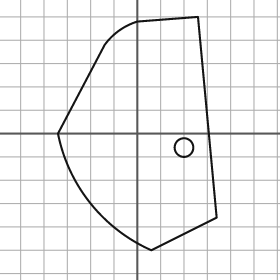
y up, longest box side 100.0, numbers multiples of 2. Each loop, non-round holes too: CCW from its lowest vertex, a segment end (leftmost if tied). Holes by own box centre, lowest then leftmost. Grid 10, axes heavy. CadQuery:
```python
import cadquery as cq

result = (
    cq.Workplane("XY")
    .moveTo(6.0, -50.0)
    .lineTo(34.0, -36.0)
    .lineTo(26.0, 50.0)
    .lineTo(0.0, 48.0)
    .threePointArc((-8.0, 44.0), (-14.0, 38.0))
    .lineTo(-34.0, 0.0)
    .threePointArc((-20.0, -30.0), (6.0, -50.0))
    .close()
    .moveTo(20.0, -6.0)
    .circle(4.0)
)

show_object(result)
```